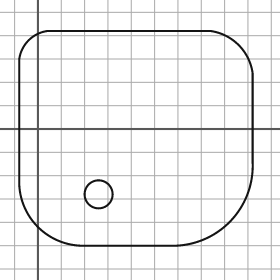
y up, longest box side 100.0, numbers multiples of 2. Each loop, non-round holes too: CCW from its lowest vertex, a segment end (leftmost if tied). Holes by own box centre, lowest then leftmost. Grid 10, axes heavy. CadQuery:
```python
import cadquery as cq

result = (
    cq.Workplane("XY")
    .moveTo(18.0, -50.0)
    .lineTo(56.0, -50.0)
    .threePointArc((82.0, -40.0), (92.0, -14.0))
    .lineTo(92.0, 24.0)
    .threePointArc((86.0, 36.0), (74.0, 42.0))
    .lineTo(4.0, 42.0)
    .threePointArc((-4.0, 38.0), (-8.0, 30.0))
    .lineTo(-8.0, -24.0)
    .threePointArc((0.0, -42.0), (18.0, -50.0))
    .close()
    .moveTo(26.0, -28.0)
    .circle(6.0)
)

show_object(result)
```